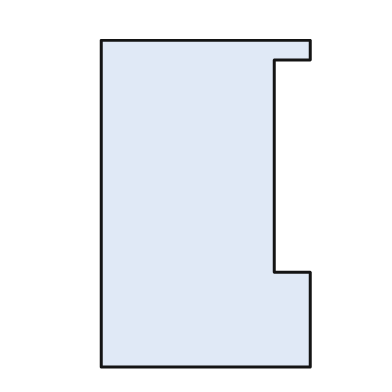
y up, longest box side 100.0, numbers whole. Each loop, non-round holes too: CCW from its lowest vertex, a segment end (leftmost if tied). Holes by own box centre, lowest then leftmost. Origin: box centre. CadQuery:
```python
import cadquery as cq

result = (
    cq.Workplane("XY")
    .moveTo(-32.0, -50.0)
    .lineTo(32.0, -50.0)
    .lineTo(32.0, -21.0)
    .lineTo(21.0, -21.0)
    .lineTo(21.0, 44.0)
    .lineTo(32.0, 44.0)
    .lineTo(32.0, 50.0)
    .lineTo(-32.0, 50.0)
    .close()
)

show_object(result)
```